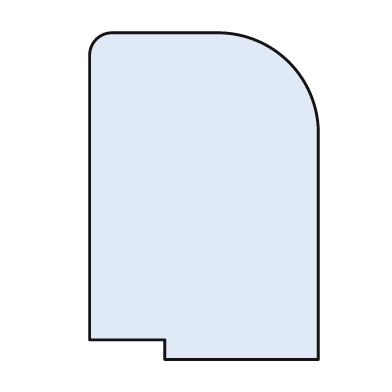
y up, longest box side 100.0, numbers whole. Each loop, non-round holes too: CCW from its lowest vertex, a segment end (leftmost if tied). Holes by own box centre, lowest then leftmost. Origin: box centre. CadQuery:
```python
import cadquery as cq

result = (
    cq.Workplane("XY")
    .moveTo(-12.0, -50.0)
    .lineTo(35.0, -50.0)
    .lineTo(35.0, 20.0)
    .threePointArc((26.0, 41.0), (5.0, 50.0))
    .lineTo(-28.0, 50.0)
    .threePointArc((-33.0, 48.0), (-35.0, 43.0))
    .lineTo(-35.0, -44.0)
    .lineTo(-12.0, -44.0)
    .close()
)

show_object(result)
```